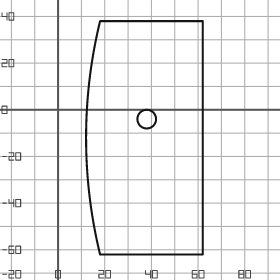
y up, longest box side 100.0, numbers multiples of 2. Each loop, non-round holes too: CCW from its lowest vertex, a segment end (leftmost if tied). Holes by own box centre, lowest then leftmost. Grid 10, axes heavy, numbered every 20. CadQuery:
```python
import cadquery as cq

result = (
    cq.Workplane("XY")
    .moveTo(18.0, -62.0)
    .lineTo(62.0, -62.0)
    .lineTo(62.0, 38.0)
    .lineTo(18.0, 38.0)
    .threePointArc((12.0, -12.0), (18.0, -62.0))
    .close()
    .moveTo(38.0, -4.0)
    .circle(4.0)
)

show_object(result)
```